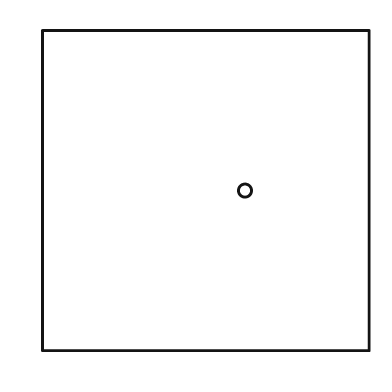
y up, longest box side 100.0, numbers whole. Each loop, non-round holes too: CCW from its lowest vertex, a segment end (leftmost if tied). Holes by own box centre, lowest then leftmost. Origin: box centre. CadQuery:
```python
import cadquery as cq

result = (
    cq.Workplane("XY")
    .moveTo(-50.0, -49.0)
    .lineTo(50.0, -49.0)
    .lineTo(50.0, 49.0)
    .lineTo(-50.0, 49.0)
    .close()
    .moveTo(12.0, 0.0)
    .circle(2.0)
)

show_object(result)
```